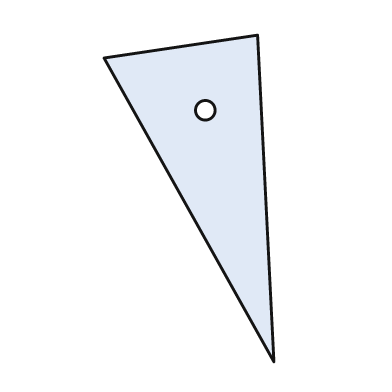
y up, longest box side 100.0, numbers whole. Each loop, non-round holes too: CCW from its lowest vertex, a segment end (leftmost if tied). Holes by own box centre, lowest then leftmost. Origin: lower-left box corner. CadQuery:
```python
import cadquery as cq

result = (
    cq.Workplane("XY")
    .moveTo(52.0, 0.0)
    .lineTo(47.0, 100.0)
    .lineTo(0.0, 93.0)
    .close()
    .moveTo(31.0, 77.0)
    .circle(3.0)
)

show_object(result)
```